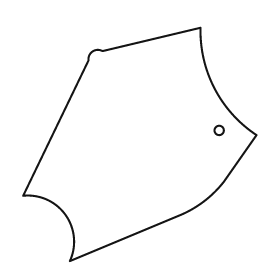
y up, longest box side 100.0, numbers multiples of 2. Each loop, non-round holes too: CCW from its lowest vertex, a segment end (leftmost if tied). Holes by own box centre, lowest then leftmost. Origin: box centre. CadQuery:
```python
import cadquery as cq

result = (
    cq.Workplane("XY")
    .moveTo(-30.0, -50.0)
    .lineTo(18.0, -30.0)
    .threePointArc((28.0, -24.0), (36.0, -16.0))
    .lineTo(50.0, 4.0)
    .threePointArc((32.0, 24.0), (26.0, 50.0))
    .lineTo(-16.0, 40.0)
    .threePointArc((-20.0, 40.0), (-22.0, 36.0))
    .lineTo(-50.0, -22.0)
    .threePointArc((-32.0, -30.0), (-30.0, -50.0))
    .close()
    .moveTo(34.0, 6.0)
    .circle(2.0)
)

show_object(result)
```